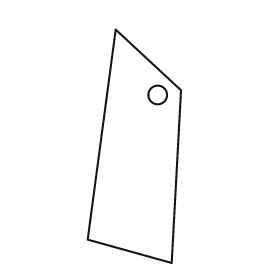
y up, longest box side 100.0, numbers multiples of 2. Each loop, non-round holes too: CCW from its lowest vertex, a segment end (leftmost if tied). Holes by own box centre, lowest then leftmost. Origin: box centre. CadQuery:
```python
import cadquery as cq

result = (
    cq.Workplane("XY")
    .moveTo(16.0, -50.0)
    .lineTo(20.0, 24.0)
    .lineTo(-8.0, 50.0)
    .lineTo(-20.0, -40.0)
    .close()
    .moveTo(10.0, 22.0)
    .circle(4.0)
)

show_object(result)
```